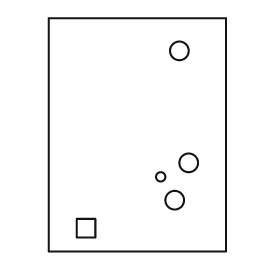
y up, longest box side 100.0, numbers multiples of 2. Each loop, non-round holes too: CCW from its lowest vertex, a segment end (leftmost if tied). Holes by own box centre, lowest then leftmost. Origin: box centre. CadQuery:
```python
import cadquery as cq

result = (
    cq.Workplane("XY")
    .moveTo(-38.0, -50.0)
    .lineTo(38.0, -50.0)
    .lineTo(38.0, 50.0)
    .lineTo(-38.0, 50.0)
    .close()
    .moveTo(-26.0, -44.0)
    .lineTo(-18.0, -44.0)
    .lineTo(-18.0, -36.0)
    .lineTo(-26.0, -36.0)
    .close()
    .moveTo(16.0, -28.0)
    .circle(4.0)
    .moveTo(10.0, -18.0)
    .circle(2.0)
    .moveTo(22.0, -12.0)
    .circle(4.0)
    .moveTo(18.0, 36.0)
    .circle(4.0)
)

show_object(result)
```